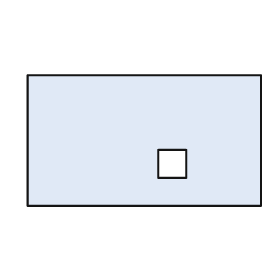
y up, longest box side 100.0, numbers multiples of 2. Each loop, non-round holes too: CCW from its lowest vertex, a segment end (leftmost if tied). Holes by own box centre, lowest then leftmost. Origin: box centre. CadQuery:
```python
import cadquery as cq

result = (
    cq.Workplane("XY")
    .moveTo(-50.0, -28.0)
    .lineTo(50.0, -28.0)
    .lineTo(50.0, 28.0)
    .lineTo(-50.0, 28.0)
    .close()
    .moveTo(6.0, -16.0)
    .lineTo(18.0, -16.0)
    .lineTo(18.0, -4.0)
    .lineTo(6.0, -4.0)
    .close()
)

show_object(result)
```